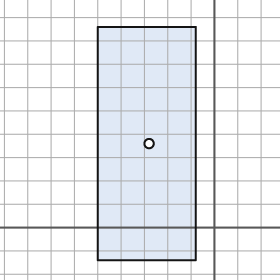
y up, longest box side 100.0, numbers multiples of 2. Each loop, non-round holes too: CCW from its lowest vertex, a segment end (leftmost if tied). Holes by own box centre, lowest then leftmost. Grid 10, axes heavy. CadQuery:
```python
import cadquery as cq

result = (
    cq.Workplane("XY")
    .moveTo(-50.0, -14.0)
    .lineTo(-8.0, -14.0)
    .lineTo(-8.0, 86.0)
    .lineTo(-50.0, 86.0)
    .close()
    .moveTo(-28.0, 36.0)
    .circle(2.0)
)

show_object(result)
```